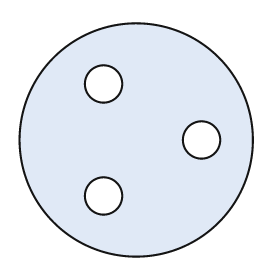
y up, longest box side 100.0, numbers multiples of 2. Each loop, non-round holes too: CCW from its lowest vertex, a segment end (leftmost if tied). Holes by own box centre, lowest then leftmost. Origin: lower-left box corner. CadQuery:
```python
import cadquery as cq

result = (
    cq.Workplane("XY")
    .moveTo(50.0, 50.0)
    .circle(50.0)
    .moveTo(36.0, 26.0)
    .circle(8.0)
    .moveTo(78.0, 50.0)
    .circle(8.0)
    .moveTo(36.0, 74.0)
    .circle(8.0)
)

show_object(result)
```